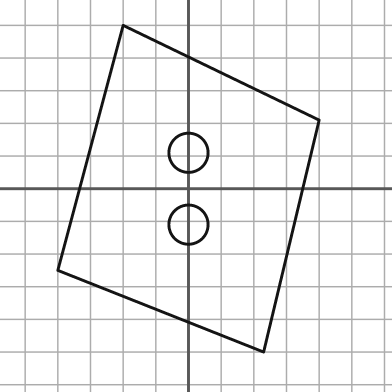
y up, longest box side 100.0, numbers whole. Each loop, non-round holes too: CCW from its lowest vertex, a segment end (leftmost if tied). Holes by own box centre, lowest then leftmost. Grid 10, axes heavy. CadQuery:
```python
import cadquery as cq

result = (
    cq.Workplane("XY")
    .moveTo(23.0, -50.0)
    .lineTo(40.0, 21.0)
    .lineTo(-20.0, 50.0)
    .lineTo(-40.0, -25.0)
    .close()
    .moveTo(0.0, -11.0)
    .circle(6.0)
    .moveTo(0.0, 11.0)
    .circle(6.0)
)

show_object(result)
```